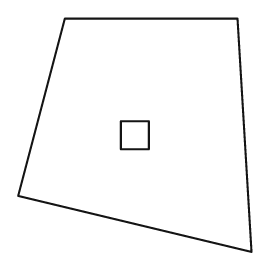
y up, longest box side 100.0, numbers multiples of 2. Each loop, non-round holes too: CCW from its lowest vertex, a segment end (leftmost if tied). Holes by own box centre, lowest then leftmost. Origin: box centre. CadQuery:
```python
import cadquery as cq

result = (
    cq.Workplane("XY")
    .moveTo(50.0, -50.0)
    .lineTo(44.0, 50.0)
    .lineTo(-30.0, 50.0)
    .lineTo(-50.0, -26.0)
    .close()
    .moveTo(-6.0, -6.0)
    .lineTo(6.0, -6.0)
    .lineTo(6.0, 6.0)
    .lineTo(-6.0, 6.0)
    .close()
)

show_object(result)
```